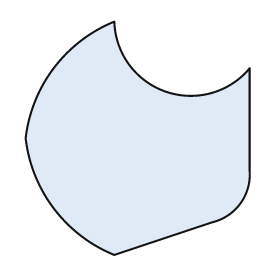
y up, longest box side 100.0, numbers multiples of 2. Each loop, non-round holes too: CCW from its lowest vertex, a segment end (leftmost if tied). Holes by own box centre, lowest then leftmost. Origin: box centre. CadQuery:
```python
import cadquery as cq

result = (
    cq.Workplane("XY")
    .moveTo(-10.0, -50.0)
    .lineTo(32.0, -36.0)
    .threePointArc((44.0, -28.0), (48.0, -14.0))
    .lineTo(48.0, 30.0)
    .threePointArc((12.0, 20.0), (-10.0, 50.0))
    .threePointArc((-36.0, 30.0), (-48.0, 0.0))
    .threePointArc((-36.0, -30.0), (-10.0, -50.0))
    .close()
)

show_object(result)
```